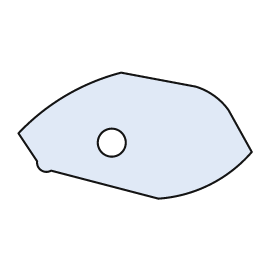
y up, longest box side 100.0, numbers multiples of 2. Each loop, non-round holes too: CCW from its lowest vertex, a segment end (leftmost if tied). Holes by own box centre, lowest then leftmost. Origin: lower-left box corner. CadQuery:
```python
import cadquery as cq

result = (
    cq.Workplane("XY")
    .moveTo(60.0, 0.0)
    .threePointArc((82.0, 6.0), (100.0, 20.0))
    .lineTo(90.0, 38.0)
    .threePointArc((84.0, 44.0), (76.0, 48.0))
    .lineTo(44.0, 54.0)
    .threePointArc((20.0, 44.0), (0.0, 28.0))
    .lineTo(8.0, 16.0)
    .threePointArc((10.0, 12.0), (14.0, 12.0))
    .close()
    .moveTo(40.0, 24.0)
    .circle(6.0)
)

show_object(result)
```